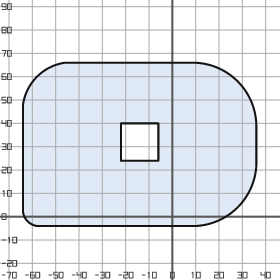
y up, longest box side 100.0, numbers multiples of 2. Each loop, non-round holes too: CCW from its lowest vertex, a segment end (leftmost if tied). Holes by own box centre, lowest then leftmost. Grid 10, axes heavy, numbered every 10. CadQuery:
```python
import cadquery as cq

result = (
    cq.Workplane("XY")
    .moveTo(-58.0, -4.0)
    .lineTo(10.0, -4.0)
    .threePointArc((28.0, 4.0), (36.0, 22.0))
    .lineTo(36.0, 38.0)
    .threePointArc((28.0, 58.0), (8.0, 66.0))
    .lineTo(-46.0, 66.0)
    .threePointArc((-58.0, 60.0), (-64.0, 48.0))
    .lineTo(-64.0, 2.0)
    .threePointArc((-62.0, -2.0), (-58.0, -4.0))
    .close()
    .moveTo(-22.0, 24.0)
    .lineTo(-6.0, 24.0)
    .lineTo(-6.0, 40.0)
    .lineTo(-22.0, 40.0)
    .close()
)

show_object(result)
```